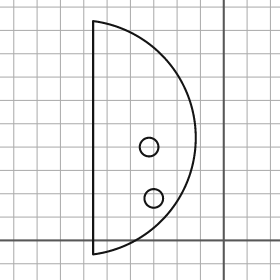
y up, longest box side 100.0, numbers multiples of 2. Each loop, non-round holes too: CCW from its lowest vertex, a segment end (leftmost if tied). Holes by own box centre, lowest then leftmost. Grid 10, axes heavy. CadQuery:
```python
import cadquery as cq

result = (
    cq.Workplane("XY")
    .moveTo(-56.0, -6.0)
    .threePointArc((-12.0, 44.0), (-56.0, 94.0))
    .close()
    .moveTo(-30.0, 18.0)
    .circle(4.0)
    .moveTo(-32.0, 40.0)
    .circle(4.0)
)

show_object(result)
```